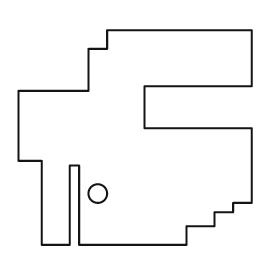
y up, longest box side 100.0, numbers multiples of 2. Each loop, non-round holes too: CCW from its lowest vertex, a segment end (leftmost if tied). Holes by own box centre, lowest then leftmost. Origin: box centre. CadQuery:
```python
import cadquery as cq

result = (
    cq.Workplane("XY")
    .moveTo(-40.0, -46.0)
    .lineTo(-28.0, -46.0)
    .lineTo(-28.0, -12.0)
    .lineTo(-24.0, -12.0)
    .lineTo(-24.0, -46.0)
    .lineTo(22.0, -46.0)
    .lineTo(22.0, -38.0)
    .lineTo(34.0, -38.0)
    .lineTo(34.0, -32.0)
    .lineTo(42.0, -32.0)
    .lineTo(42.0, -28.0)
    .lineTo(50.0, -28.0)
    .lineTo(50.0, 4.0)
    .lineTo(4.0, 4.0)
    .lineTo(4.0, 22.0)
    .lineTo(50.0, 22.0)
    .lineTo(50.0, 46.0)
    .lineTo(-12.0, 46.0)
    .lineTo(-12.0, 38.0)
    .lineTo(-20.0, 38.0)
    .lineTo(-20.0, 20.0)
    .lineTo(-50.0, 20.0)
    .lineTo(-50.0, -10.0)
    .lineTo(-40.0, -10.0)
    .close()
    .moveTo(-16.0, -24.0)
    .circle(4.0)
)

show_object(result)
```